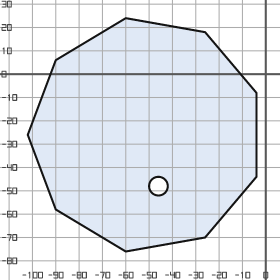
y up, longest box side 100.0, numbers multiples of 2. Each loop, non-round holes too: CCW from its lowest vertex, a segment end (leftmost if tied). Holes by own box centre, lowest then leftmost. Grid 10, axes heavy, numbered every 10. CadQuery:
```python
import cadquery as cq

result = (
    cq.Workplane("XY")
    .moveTo(-60.0, -76.0)
    .lineTo(-26.0, -70.0)
    .lineTo(-4.0, -44.0)
    .lineTo(-4.0, -8.0)
    .lineTo(-26.0, 18.0)
    .lineTo(-60.0, 24.0)
    .lineTo(-90.0, 6.0)
    .lineTo(-102.0, -26.0)
    .lineTo(-90.0, -58.0)
    .close()
    .moveTo(-46.0, -48.0)
    .circle(4.0)
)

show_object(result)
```